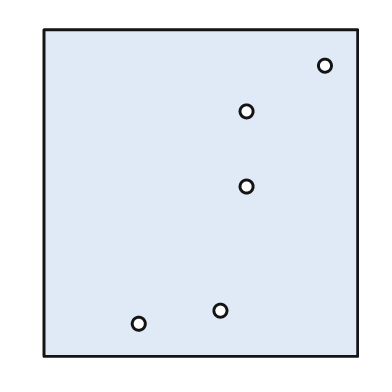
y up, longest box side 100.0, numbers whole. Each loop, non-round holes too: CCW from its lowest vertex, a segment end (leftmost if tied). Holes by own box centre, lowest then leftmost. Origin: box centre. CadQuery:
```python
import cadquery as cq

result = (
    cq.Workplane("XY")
    .moveTo(-48.0, -50.0)
    .lineTo(48.0, -50.0)
    .lineTo(48.0, 50.0)
    .lineTo(-48.0, 50.0)
    .close()
    .moveTo(-19.0, -40.0)
    .circle(2.0)
    .moveTo(6.0, -36.0)
    .circle(2.0)
    .moveTo(14.0, 2.0)
    .circle(2.0)
    .moveTo(14.0, 25.0)
    .circle(2.0)
    .moveTo(38.0, 39.0)
    .circle(2.0)
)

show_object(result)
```